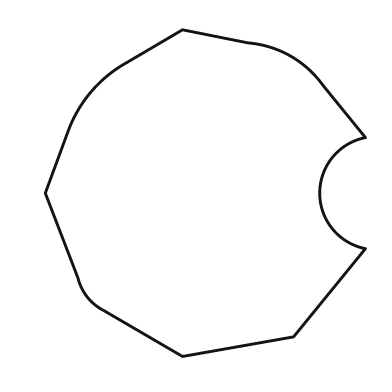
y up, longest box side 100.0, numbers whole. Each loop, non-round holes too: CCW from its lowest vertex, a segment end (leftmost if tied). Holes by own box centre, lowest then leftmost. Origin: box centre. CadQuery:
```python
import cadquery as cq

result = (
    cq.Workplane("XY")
    .moveTo(-7.0, -50.0)
    .lineTo(27.0, -44.0)
    .lineTo(49.0, -17.0)
    .threePointArc((35.0, 0.0), (49.0, 17.0))
    .lineTo(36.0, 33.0)
    .threePointArc((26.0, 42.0), (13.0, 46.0))
    .lineTo(-7.0, 50.0)
    .lineTo(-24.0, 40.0)
    .threePointArc((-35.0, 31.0), (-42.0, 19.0))
    .lineTo(-49.0, 0.0)
    .lineTo(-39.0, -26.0)
    .threePointArc((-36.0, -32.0), (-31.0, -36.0))
    .close()
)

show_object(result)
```